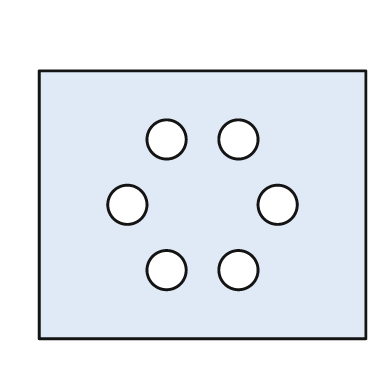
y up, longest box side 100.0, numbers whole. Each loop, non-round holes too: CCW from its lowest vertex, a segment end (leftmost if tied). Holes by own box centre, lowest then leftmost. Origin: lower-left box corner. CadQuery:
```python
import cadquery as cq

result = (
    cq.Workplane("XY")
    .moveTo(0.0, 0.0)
    .lineTo(100.0, 0.0)
    .lineTo(100.0, 82.0)
    .lineTo(0.0, 82.0)
    .close()
    .moveTo(39.0, 21.0)
    .circle(6.0)
    .moveTo(61.0, 21.0)
    .circle(6.0)
    .moveTo(27.0, 41.0)
    .circle(6.0)
    .moveTo(73.0, 41.0)
    .circle(6.0)
    .moveTo(39.0, 61.0)
    .circle(6.0)
    .moveTo(61.0, 61.0)
    .circle(6.0)
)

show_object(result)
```